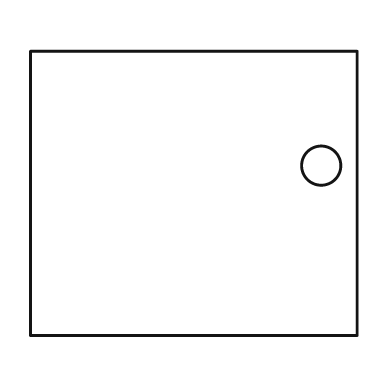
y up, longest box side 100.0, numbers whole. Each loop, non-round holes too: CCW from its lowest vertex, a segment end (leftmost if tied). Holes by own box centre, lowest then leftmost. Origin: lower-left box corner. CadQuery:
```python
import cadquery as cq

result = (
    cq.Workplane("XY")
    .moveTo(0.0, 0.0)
    .lineTo(100.0, 0.0)
    .lineTo(100.0, 87.0)
    .lineTo(0.0, 87.0)
    .close()
    .moveTo(89.0, 52.0)
    .circle(6.0)
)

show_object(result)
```